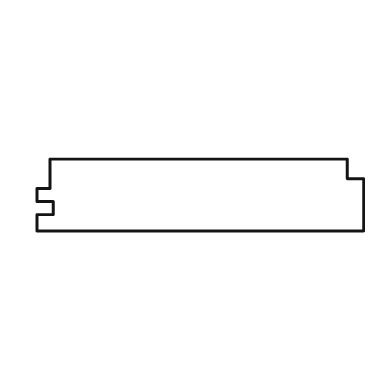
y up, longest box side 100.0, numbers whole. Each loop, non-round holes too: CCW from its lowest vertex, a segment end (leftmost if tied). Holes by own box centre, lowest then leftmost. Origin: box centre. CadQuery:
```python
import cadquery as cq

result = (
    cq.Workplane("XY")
    .moveTo(-50.0, -11.0)
    .lineTo(50.0, -11.0)
    .lineTo(50.0, 5.0)
    .lineTo(45.0, 5.0)
    .lineTo(45.0, 11.0)
    .lineTo(-46.0, 11.0)
    .lineTo(-46.0, 2.0)
    .lineTo(-50.0, 2.0)
    .lineTo(-50.0, -2.0)
    .lineTo(-45.0, -2.0)
    .lineTo(-45.0, -6.0)
    .lineTo(-50.0, -6.0)
    .close()
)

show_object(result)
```